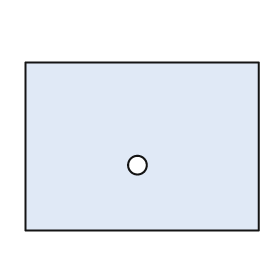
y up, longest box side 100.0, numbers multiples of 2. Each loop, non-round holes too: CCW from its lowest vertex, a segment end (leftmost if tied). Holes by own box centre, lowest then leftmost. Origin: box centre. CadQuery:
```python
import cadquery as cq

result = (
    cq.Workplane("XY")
    .moveTo(-50.0, -36.0)
    .lineTo(50.0, -36.0)
    .lineTo(50.0, 36.0)
    .lineTo(-50.0, 36.0)
    .close()
    .moveTo(-2.0, -8.0)
    .circle(4.0)
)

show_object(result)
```